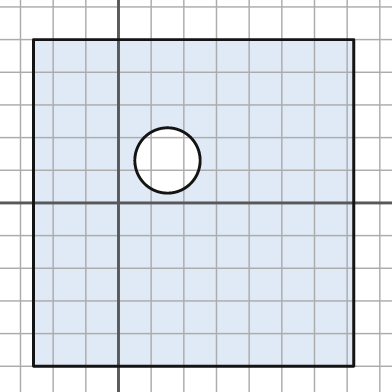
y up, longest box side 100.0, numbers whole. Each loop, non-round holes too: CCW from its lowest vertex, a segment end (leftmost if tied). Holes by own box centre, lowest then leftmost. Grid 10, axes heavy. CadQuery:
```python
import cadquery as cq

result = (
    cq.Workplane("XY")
    .moveTo(-26.0, -50.0)
    .lineTo(72.0, -50.0)
    .lineTo(72.0, 50.0)
    .lineTo(-26.0, 50.0)
    .close()
    .moveTo(15.0, 13.0)
    .circle(10.0)
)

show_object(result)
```